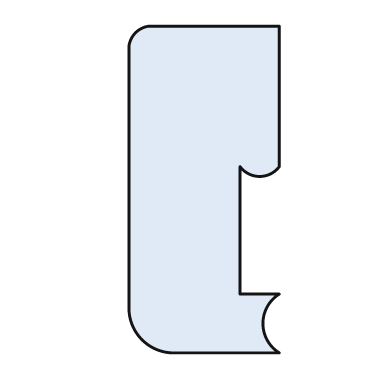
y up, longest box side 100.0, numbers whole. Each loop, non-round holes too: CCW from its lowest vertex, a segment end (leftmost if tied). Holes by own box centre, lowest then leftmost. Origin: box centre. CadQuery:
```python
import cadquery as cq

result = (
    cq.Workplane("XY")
    .moveTo(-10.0, -50.0)
    .lineTo(23.0, -50.0)
    .threePointArc((18.0, -41.0), (23.0, -32.0))
    .lineTo(11.0, -32.0)
    .lineTo(11.0, 7.0)
    .threePointArc((17.0, 4.0), (23.0, 7.0))
    .lineTo(23.0, 50.0)
    .lineTo(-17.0, 50.0)
    .threePointArc((-21.0, 48.0), (-23.0, 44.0))
    .lineTo(-23.0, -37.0)
    .threePointArc((-19.0, -46.0), (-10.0, -50.0))
    .close()
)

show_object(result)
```